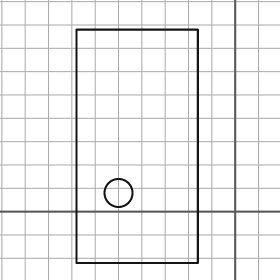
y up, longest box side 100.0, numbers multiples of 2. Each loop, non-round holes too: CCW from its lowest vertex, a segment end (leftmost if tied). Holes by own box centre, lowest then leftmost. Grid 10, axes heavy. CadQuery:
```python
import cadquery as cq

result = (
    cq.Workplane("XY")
    .moveTo(-68.0, -22.0)
    .lineTo(-16.0, -22.0)
    .lineTo(-16.0, 78.0)
    .lineTo(-68.0, 78.0)
    .close()
    .moveTo(-50.0, 8.0)
    .circle(6.0)
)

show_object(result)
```